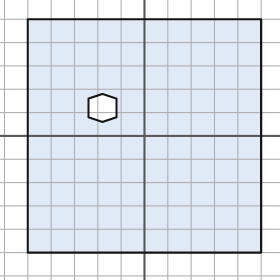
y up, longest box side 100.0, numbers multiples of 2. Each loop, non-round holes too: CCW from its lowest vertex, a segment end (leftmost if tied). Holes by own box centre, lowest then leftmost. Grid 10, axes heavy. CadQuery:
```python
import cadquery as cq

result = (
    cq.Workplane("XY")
    .moveTo(-50.0, -50.0)
    .lineTo(50.0, -50.0)
    .lineTo(50.0, 50.0)
    .lineTo(-50.0, 50.0)
    .close()
    .moveTo(-18.0, 6.0)
    .lineTo(-12.0, 8.0)
    .lineTo(-12.0, 16.0)
    .lineTo(-18.0, 18.0)
    .lineTo(-24.0, 16.0)
    .lineTo(-24.0, 8.0)
    .close()
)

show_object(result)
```